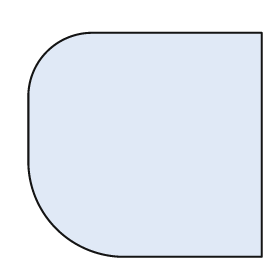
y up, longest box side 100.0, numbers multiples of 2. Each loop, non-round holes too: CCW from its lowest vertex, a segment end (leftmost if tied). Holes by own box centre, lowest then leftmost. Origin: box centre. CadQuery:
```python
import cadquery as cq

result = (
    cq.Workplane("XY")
    .moveTo(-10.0, -48.0)
    .lineTo(50.0, -48.0)
    .lineTo(50.0, 48.0)
    .lineTo(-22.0, 48.0)
    .threePointArc((-42.0, 40.0), (-50.0, 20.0))
    .lineTo(-50.0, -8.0)
    .threePointArc((-38.0, -36.0), (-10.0, -48.0))
    .close()
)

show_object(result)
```